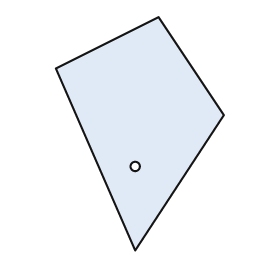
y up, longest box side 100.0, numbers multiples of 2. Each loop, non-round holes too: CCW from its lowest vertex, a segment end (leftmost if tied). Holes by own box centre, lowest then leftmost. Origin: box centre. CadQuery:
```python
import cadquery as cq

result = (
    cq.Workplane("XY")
    .moveTo(-2.0, -50.0)
    .lineTo(36.0, 8.0)
    .lineTo(8.0, 50.0)
    .lineTo(-36.0, 28.0)
    .close()
    .moveTo(-2.0, -14.0)
    .circle(2.0)
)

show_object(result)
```